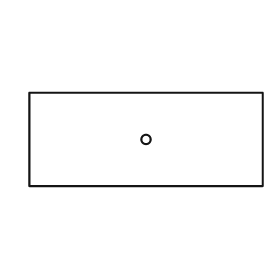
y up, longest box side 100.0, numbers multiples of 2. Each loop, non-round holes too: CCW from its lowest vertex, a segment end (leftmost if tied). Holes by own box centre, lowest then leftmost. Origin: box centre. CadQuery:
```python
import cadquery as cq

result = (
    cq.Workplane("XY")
    .moveTo(-50.0, -20.0)
    .lineTo(50.0, -20.0)
    .lineTo(50.0, 20.0)
    .lineTo(-50.0, 20.0)
    .close()
    .moveTo(0.0, 0.0)
    .circle(2.0)
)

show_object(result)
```